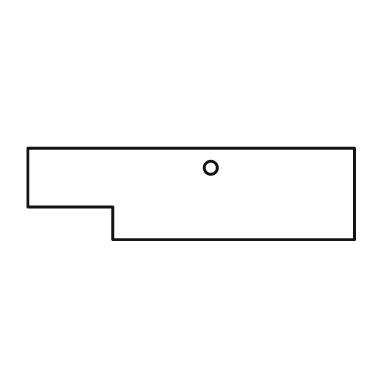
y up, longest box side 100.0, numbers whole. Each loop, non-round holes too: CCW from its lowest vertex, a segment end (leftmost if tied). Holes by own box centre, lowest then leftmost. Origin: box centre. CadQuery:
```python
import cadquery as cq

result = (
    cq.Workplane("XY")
    .moveTo(-24.0, -14.0)
    .lineTo(50.0, -14.0)
    .lineTo(50.0, 14.0)
    .lineTo(-50.0, 14.0)
    .lineTo(-50.0, -4.0)
    .lineTo(-24.0, -4.0)
    .close()
    .moveTo(6.0, 8.0)
    .circle(2.0)
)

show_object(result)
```